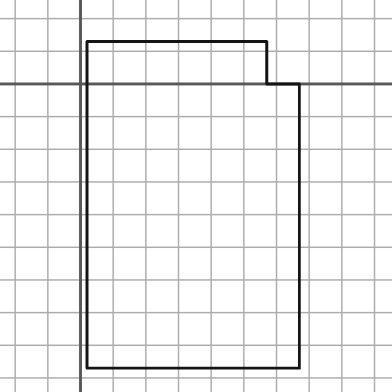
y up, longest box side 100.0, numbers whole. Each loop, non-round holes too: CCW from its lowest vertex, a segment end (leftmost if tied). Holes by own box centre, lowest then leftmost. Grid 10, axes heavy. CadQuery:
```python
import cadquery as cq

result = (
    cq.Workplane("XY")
    .moveTo(2.0, -87.0)
    .lineTo(67.0, -87.0)
    .lineTo(67.0, 0.0)
    .lineTo(57.0, 0.0)
    .lineTo(57.0, 13.0)
    .lineTo(2.0, 13.0)
    .close()
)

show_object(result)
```